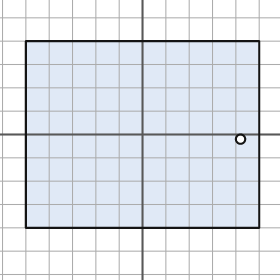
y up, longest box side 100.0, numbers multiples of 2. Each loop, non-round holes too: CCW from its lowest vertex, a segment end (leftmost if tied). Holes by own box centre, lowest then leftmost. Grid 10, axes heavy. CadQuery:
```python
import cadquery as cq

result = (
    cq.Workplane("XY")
    .moveTo(-50.0, -40.0)
    .lineTo(50.0, -40.0)
    .lineTo(50.0, 40.0)
    .lineTo(-50.0, 40.0)
    .close()
    .moveTo(42.0, -2.0)
    .circle(2.0)
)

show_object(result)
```